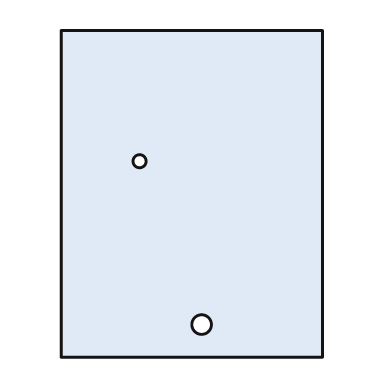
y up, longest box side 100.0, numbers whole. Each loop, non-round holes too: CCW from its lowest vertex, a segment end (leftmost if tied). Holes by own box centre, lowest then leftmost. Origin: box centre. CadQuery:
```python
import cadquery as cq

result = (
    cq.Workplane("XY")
    .moveTo(-40.0, -50.0)
    .lineTo(40.0, -50.0)
    .lineTo(40.0, 50.0)
    .lineTo(-40.0, 50.0)
    .close()
    .moveTo(3.0, -40.0)
    .circle(3.0)
    .moveTo(-16.0, 10.0)
    .circle(2.0)
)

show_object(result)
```